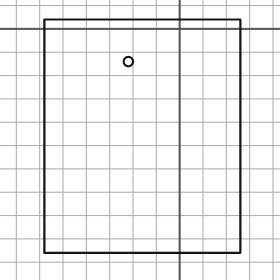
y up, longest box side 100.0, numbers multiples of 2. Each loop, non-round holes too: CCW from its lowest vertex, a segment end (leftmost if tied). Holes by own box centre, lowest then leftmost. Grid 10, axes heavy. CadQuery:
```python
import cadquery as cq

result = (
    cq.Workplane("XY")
    .moveTo(-58.0, -96.0)
    .lineTo(26.0, -96.0)
    .lineTo(26.0, 4.0)
    .lineTo(-58.0, 4.0)
    .close()
    .moveTo(-22.0, -14.0)
    .circle(2.0)
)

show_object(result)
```